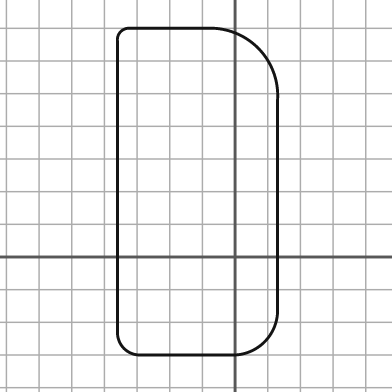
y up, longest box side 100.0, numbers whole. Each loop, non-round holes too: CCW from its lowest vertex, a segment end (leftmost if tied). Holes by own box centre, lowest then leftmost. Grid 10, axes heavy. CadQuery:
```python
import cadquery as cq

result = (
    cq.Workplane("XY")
    .moveTo(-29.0, -30.0)
    .lineTo(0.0, -30.0)
    .threePointArc((9.0, -26.0), (13.0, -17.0))
    .lineTo(13.0, 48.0)
    .threePointArc((7.0, 64.0), (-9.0, 70.0))
    .lineTo(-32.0, 70.0)
    .threePointArc((-35.0, 69.0), (-36.0, 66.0))
    .lineTo(-36.0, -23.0)
    .threePointArc((-34.0, -28.0), (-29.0, -30.0))
    .close()
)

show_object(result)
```